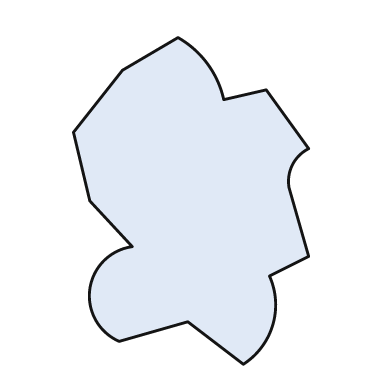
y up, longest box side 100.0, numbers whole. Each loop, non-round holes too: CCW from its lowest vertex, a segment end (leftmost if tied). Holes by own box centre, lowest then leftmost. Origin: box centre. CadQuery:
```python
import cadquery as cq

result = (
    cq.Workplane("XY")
    .moveTo(16.0, -50.0)
    .threePointArc((25.0, -38.0), (24.0, -23.0))
    .lineTo(36.0, -17.0)
    .lineTo(30.0, 4.0)
    .threePointArc((31.0, 11.0), (36.0, 16.0))
    .lineTo(23.0, 34.0)
    .lineTo(10.0, 31.0)
    .threePointArc((5.0, 42.0), (-4.0, 50.0))
    .lineTo(-21.0, 40.0)
    .lineTo(-36.0, 21.0)
    .lineTo(-31.0, 0.0)
    .lineTo(-18.0, -14.0)
    .threePointArc((-31.0, -27.0), (-22.0, -43.0))
    .lineTo(-1.0, -37.0)
    .close()
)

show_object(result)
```